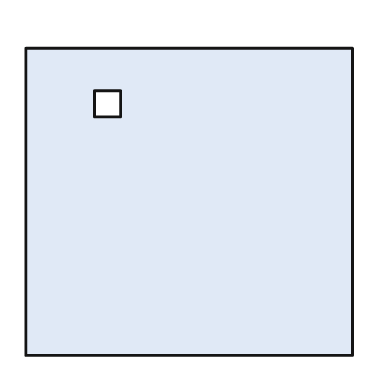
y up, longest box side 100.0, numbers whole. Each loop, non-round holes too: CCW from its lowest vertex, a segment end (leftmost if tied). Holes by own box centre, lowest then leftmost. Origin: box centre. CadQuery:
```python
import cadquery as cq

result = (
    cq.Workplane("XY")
    .moveTo(-50.0, -47.0)
    .lineTo(50.0, -47.0)
    .lineTo(50.0, 47.0)
    .lineTo(-50.0, 47.0)
    .close()
    .moveTo(-29.0, 26.0)
    .lineTo(-21.0, 26.0)
    .lineTo(-21.0, 34.0)
    .lineTo(-29.0, 34.0)
    .close()
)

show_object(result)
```